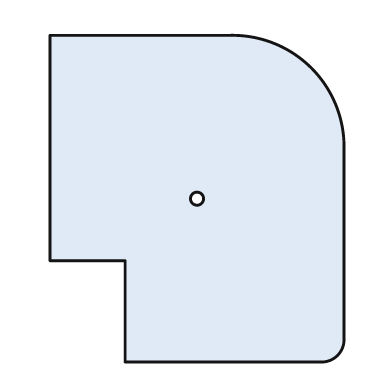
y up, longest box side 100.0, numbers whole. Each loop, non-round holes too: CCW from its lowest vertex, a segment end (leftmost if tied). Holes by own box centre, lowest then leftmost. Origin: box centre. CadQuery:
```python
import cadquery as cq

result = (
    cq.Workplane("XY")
    .moveTo(-22.0, -50.0)
    .lineTo(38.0, -50.0)
    .threePointArc((43.0, -48.0), (45.0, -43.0))
    .lineTo(45.0, 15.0)
    .threePointArc((35.0, 40.0), (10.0, 50.0))
    .lineTo(-45.0, 50.0)
    .lineTo(-45.0, -19.0)
    .lineTo(-22.0, -19.0)
    .close()
    .moveTo(0.0, 0.0)
    .circle(2.0)
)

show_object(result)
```